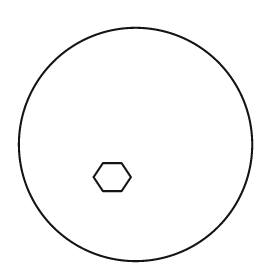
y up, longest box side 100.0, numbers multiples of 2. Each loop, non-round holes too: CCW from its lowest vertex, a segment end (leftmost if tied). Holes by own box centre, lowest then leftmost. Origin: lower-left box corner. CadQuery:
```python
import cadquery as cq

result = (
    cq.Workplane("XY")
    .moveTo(50.0, 50.0)
    .circle(50.0)
    .moveTo(36.0, 30.0)
    .lineTo(44.0, 30.0)
    .lineTo(48.0, 36.0)
    .lineTo(44.0, 42.0)
    .lineTo(36.0, 42.0)
    .lineTo(32.0, 36.0)
    .close()
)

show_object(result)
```